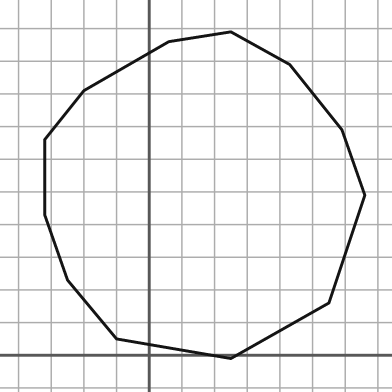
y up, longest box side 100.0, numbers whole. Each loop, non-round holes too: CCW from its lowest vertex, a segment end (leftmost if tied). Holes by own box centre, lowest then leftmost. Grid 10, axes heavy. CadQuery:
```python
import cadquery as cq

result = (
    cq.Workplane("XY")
    .moveTo(25.0, -1.0)
    .lineTo(55.0, 16.0)
    .lineTo(66.0, 49.0)
    .lineTo(59.0, 69.0)
    .lineTo(43.0, 89.0)
    .lineTo(25.0, 99.0)
    .lineTo(6.0, 96.0)
    .lineTo(-20.0, 81.0)
    .lineTo(-32.0, 66.0)
    .lineTo(-32.0, 43.0)
    .lineTo(-25.0, 23.0)
    .lineTo(-10.0, 5.0)
    .close()
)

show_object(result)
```